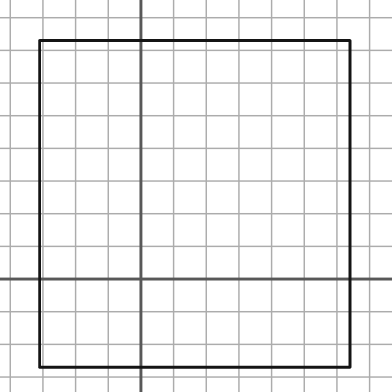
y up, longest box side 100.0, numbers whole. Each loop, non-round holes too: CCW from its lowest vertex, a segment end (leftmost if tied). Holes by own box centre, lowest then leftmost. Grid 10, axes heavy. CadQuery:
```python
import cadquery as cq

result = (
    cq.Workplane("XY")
    .moveTo(-31.0, -27.0)
    .lineTo(64.0, -27.0)
    .lineTo(64.0, 73.0)
    .lineTo(-31.0, 73.0)
    .close()
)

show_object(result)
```